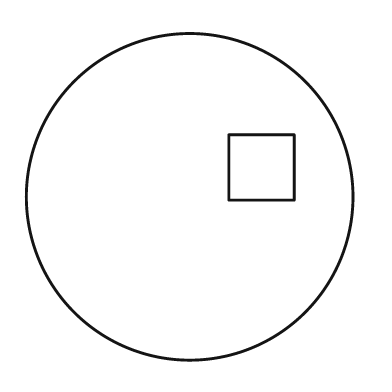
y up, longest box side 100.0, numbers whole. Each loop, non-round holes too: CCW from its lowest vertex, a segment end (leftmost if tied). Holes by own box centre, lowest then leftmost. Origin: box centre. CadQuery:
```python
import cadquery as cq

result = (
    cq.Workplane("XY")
    .moveTo(0.0, 0.0)
    .circle(50.0)
    .moveTo(12.0, -1.0)
    .lineTo(32.0, -1.0)
    .lineTo(32.0, 19.0)
    .lineTo(12.0, 19.0)
    .close()
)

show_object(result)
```